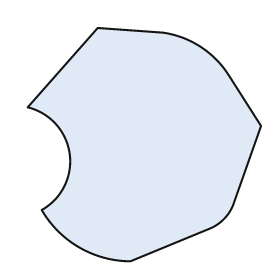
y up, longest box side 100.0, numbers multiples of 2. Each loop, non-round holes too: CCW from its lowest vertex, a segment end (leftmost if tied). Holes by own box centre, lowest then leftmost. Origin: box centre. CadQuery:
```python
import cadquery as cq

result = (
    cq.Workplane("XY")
    .moveTo(-6.0, -50.0)
    .lineTo(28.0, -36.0)
    .threePointArc((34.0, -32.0), (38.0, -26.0))
    .lineTo(50.0, 8.0)
    .lineTo(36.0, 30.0)
    .threePointArc((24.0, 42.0), (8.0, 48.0))
    .lineTo(-20.0, 50.0)
    .lineTo(-50.0, 16.0)
    .threePointArc((-32.0, -4.0), (-44.0, -28.0))
    .threePointArc((-28.0, -44.0), (-6.0, -50.0))
    .close()
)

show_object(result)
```